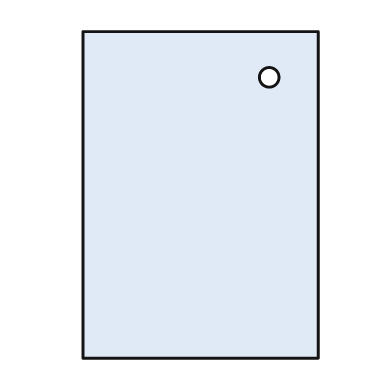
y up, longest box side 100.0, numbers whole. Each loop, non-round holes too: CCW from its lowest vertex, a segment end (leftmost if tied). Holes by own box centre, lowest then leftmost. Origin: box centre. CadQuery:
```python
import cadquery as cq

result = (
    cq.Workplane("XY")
    .moveTo(-36.0, -50.0)
    .lineTo(36.0, -50.0)
    .lineTo(36.0, 50.0)
    .lineTo(-36.0, 50.0)
    .close()
    .moveTo(21.0, 36.0)
    .circle(3.0)
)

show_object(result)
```